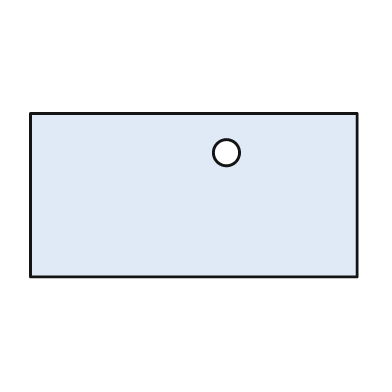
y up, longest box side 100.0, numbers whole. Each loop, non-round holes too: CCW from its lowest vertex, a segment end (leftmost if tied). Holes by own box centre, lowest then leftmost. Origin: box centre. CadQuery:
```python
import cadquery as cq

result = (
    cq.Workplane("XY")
    .moveTo(-50.0, -25.0)
    .lineTo(50.0, -25.0)
    .lineTo(50.0, 25.0)
    .lineTo(-50.0, 25.0)
    .close()
    .moveTo(10.0, 13.0)
    .circle(4.0)
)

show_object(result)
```